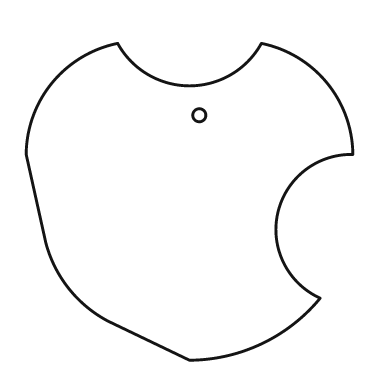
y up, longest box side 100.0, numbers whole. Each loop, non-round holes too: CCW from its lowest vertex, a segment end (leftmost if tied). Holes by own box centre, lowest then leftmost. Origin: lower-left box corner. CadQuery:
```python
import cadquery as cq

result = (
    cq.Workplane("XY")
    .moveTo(50.0, 0.0)
    .threePointArc((72.0, 5.0), (90.0, 19.0))
    .threePointArc((77.0, 45.0), (100.0, 63.0))
    .threePointArc((92.0, 85.0), (72.0, 97.0))
    .threePointArc((50.0, 84.0), (28.0, 97.0))
    .threePointArc((8.0, 85.0), (0.0, 63.0))
    .lineTo(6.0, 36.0)
    .threePointArc((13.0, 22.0), (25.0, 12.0))
    .close()
    .moveTo(53.0, 75.0)
    .circle(2.0)
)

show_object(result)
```